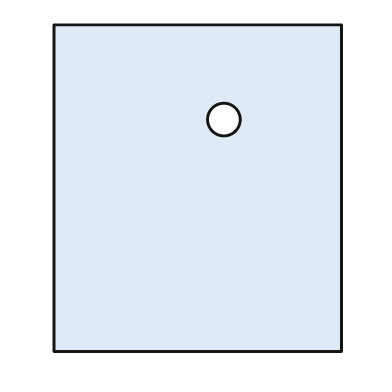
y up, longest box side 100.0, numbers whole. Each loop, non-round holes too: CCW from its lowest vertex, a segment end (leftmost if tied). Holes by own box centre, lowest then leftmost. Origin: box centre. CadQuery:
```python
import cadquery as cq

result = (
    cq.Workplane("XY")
    .moveTo(-44.0, -50.0)
    .lineTo(44.0, -50.0)
    .lineTo(44.0, 50.0)
    .lineTo(-44.0, 50.0)
    .close()
    .moveTo(8.0, 21.0)
    .circle(5.0)
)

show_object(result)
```